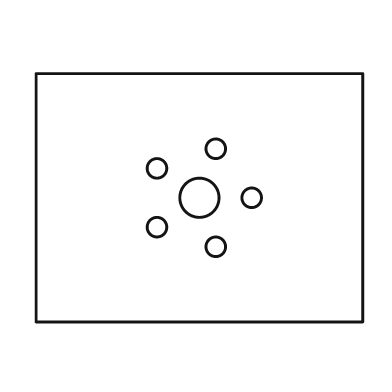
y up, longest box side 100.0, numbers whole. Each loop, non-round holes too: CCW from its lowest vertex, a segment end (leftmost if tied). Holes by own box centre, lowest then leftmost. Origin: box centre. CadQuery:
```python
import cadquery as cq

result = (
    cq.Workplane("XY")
    .moveTo(-50.0, -38.0)
    .lineTo(50.0, -38.0)
    .lineTo(50.0, 38.0)
    .lineTo(-50.0, 38.0)
    .close()
    .moveTo(5.0, -15.0)
    .circle(3.0)
    .moveTo(-13.0, -9.0)
    .circle(3.0)
    .moveTo(0.0, 0.0)
    .circle(6.0)
    .moveTo(16.0, 0.0)
    .circle(3.0)
    .moveTo(-13.0, 9.0)
    .circle(3.0)
    .moveTo(5.0, 15.0)
    .circle(3.0)
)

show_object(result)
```